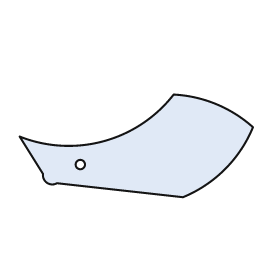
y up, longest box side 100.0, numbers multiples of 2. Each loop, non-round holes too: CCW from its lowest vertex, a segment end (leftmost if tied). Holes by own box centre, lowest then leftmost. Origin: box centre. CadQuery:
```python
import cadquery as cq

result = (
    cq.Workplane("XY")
    .moveTo(20.0, -22.0)
    .threePointArc((38.0, -10.0), (50.0, 8.0))
    .threePointArc((34.0, 18.0), (16.0, 22.0))
    .threePointArc((-14.0, 2.0), (-50.0, 4.0))
    .lineTo(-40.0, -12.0)
    .threePointArc((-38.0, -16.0), (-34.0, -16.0))
    .close()
    .moveTo(-24.0, -8.0)
    .circle(2.0)
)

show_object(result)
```